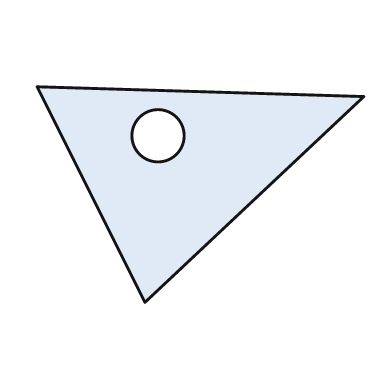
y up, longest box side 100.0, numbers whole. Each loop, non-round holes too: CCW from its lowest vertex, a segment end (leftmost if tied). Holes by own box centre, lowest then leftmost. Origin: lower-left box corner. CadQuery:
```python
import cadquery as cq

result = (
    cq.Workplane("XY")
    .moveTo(33.0, 0.0)
    .lineTo(100.0, 63.0)
    .lineTo(0.0, 66.0)
    .close()
    .moveTo(37.0, 51.0)
    .circle(8.0)
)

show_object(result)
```